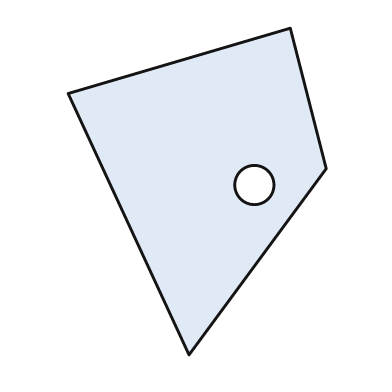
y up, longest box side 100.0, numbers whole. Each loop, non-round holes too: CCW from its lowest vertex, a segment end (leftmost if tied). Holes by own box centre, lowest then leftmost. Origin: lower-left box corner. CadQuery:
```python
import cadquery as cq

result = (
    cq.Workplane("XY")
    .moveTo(37.0, 0.0)
    .lineTo(79.0, 57.0)
    .lineTo(68.0, 100.0)
    .lineTo(0.0, 80.0)
    .close()
    .moveTo(57.0, 52.0)
    .circle(6.0)
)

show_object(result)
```